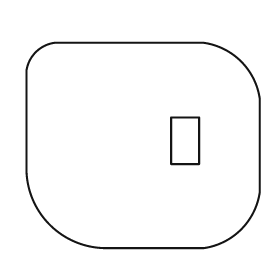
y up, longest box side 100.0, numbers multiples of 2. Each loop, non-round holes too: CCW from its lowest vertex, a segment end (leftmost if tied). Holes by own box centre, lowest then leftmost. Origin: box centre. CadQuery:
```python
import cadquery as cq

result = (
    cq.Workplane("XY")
    .moveTo(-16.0, -44.0)
    .lineTo(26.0, -44.0)
    .threePointArc((42.0, -36.0), (50.0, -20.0))
    .lineTo(50.0, 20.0)
    .threePointArc((42.0, 36.0), (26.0, 44.0))
    .lineTo(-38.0, 44.0)
    .threePointArc((-46.0, 40.0), (-50.0, 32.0))
    .lineTo(-50.0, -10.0)
    .threePointArc((-40.0, -34.0), (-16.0, -44.0))
    .close()
    .moveTo(12.0, -8.0)
    .lineTo(24.0, -8.0)
    .lineTo(24.0, 12.0)
    .lineTo(12.0, 12.0)
    .close()
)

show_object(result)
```